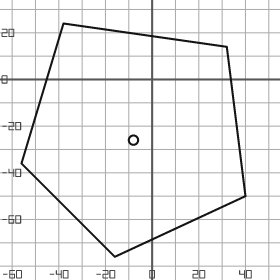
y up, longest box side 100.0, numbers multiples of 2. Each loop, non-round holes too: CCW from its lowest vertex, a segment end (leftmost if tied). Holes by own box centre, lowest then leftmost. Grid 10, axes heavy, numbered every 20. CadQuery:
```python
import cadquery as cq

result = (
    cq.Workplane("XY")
    .moveTo(-16.0, -76.0)
    .lineTo(40.0, -50.0)
    .lineTo(32.0, 14.0)
    .lineTo(-38.0, 24.0)
    .lineTo(-56.0, -36.0)
    .close()
    .moveTo(-8.0, -26.0)
    .circle(2.0)
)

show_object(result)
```